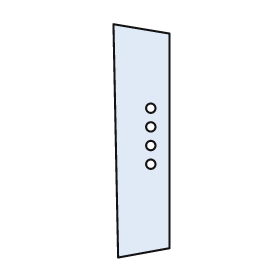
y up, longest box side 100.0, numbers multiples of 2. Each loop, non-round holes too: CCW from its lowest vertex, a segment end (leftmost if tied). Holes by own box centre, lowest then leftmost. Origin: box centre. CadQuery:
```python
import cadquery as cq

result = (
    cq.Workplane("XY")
    .moveTo(-10.0, -50.0)
    .lineTo(12.0, -46.0)
    .lineTo(12.0, 46.0)
    .lineTo(-12.0, 50.0)
    .close()
    .moveTo(4.0, -10.0)
    .circle(2.0)
    .moveTo(4.0, -2.0)
    .circle(2.0)
    .moveTo(4.0, 6.0)
    .circle(2.0)
    .moveTo(4.0, 14.0)
    .circle(2.0)
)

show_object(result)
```